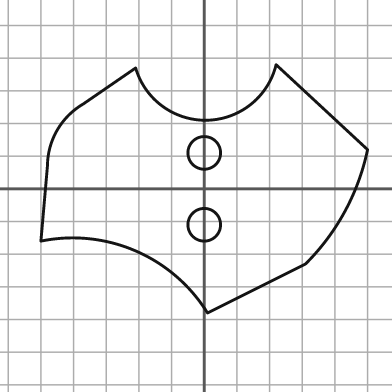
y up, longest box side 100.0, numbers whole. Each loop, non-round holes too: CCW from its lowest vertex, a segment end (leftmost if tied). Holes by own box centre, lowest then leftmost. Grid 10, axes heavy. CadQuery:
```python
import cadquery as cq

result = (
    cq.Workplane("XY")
    .moveTo(1.0, -38.0)
    .lineTo(31.0, -23.0)
    .threePointArc((43.0, -7.0), (50.0, 12.0))
    .lineTo(22.0, 38.0)
    .threePointArc((1.0, 21.0), (-21.0, 37.0))
    .lineTo(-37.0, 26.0)
    .threePointArc((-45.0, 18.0), (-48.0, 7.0))
    .lineTo(-50.0, -16.0)
    .threePointArc((-21.0, -19.0), (1.0, -38.0))
    .close()
    .moveTo(0.0, -11.0)
    .circle(5.0)
    .moveTo(0.0, 11.0)
    .circle(5.0)
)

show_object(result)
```